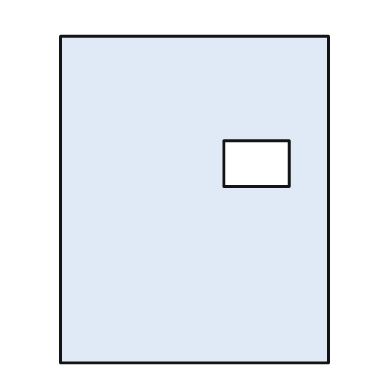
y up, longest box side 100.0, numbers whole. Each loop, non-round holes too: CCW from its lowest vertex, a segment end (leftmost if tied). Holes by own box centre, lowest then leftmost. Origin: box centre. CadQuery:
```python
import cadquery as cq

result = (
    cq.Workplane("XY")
    .moveTo(-41.0, -50.0)
    .lineTo(41.0, -50.0)
    .lineTo(41.0, 50.0)
    .lineTo(-41.0, 50.0)
    .close()
    .moveTo(9.0, 4.0)
    .lineTo(29.0, 4.0)
    .lineTo(29.0, 18.0)
    .lineTo(9.0, 18.0)
    .close()
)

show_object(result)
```